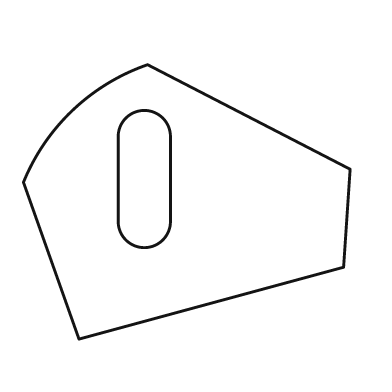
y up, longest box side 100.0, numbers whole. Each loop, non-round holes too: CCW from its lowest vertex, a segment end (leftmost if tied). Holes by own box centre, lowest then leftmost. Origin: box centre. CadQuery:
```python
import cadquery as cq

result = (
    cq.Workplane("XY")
    .moveTo(-33.0, -42.0)
    .lineTo(48.0, -20.0)
    .lineTo(50.0, 10.0)
    .lineTo(-12.0, 42.0)
    .threePointArc((-35.0, 28.0), (-50.0, 6.0))
    .close()
    .moveTo(-21.0, -6.0)
    .threePointArc((-13.0, -14.0), (-5.0, -6.0))
    .lineTo(-5.0, 20.0)
    .threePointArc((-13.0, 28.0), (-21.0, 20.0))
    .close()
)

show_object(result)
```